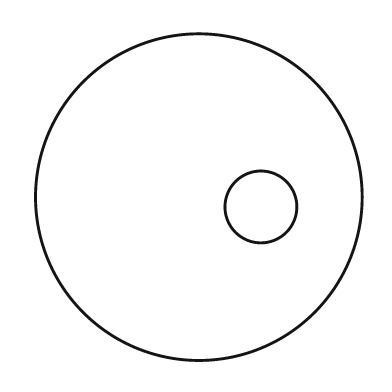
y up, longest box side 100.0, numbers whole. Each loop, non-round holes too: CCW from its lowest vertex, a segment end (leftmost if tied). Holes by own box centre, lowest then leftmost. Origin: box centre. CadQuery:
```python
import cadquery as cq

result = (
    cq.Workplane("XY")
    .moveTo(0.0, 0.0)
    .circle(50.0)
    .moveTo(19.0, -3.0)
    .circle(11.0)
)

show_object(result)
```